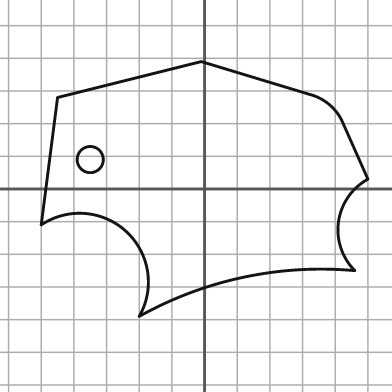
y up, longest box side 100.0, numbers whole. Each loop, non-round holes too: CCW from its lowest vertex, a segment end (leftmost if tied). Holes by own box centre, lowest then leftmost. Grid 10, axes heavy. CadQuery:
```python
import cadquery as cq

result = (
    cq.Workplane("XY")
    .moveTo(-20.0, -39.0)
    .threePointArc((12.0, -27.0), (46.0, -25.0))
    .threePointArc((41.0, -10.0), (50.0, 3.0))
    .lineTo(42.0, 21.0)
    .threePointArc((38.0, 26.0), (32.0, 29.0))
    .lineTo(-1.0, 39.0)
    .lineTo(-45.0, 28.0)
    .lineTo(-50.0, -11.0)
    .threePointArc((-24.0, -13.0), (-20.0, -39.0))
    .close()
    .moveTo(-35.0, 9.0)
    .circle(4.0)
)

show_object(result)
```